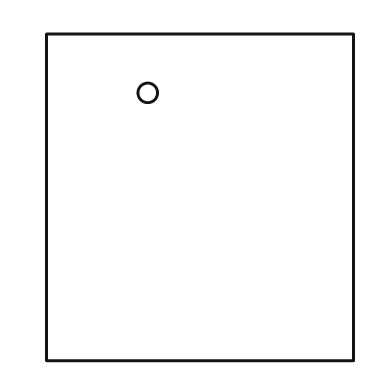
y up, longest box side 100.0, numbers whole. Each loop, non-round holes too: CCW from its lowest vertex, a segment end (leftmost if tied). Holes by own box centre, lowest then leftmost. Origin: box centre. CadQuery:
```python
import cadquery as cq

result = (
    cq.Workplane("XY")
    .moveTo(-47.0, -50.0)
    .lineTo(47.0, -50.0)
    .lineTo(47.0, 50.0)
    .lineTo(-47.0, 50.0)
    .close()
    .moveTo(-16.0, 32.0)
    .circle(3.0)
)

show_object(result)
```